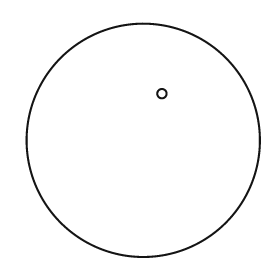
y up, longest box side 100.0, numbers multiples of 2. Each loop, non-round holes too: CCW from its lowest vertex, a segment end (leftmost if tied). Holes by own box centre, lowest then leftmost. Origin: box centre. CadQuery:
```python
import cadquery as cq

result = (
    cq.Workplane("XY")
    .moveTo(0.0, 0.0)
    .circle(50.0)
    .moveTo(8.0, 20.0)
    .circle(2.0)
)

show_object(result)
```